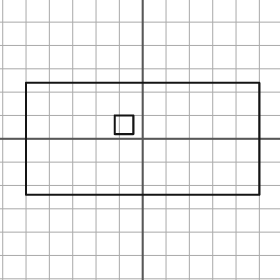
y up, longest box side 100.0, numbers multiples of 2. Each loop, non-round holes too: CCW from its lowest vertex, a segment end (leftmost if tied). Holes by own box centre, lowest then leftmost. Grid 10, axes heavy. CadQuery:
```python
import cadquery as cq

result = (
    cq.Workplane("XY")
    .moveTo(-50.0, -24.0)
    .lineTo(50.0, -24.0)
    .lineTo(50.0, 24.0)
    .lineTo(-50.0, 24.0)
    .close()
    .moveTo(-12.0, 2.0)
    .lineTo(-4.0, 2.0)
    .lineTo(-4.0, 10.0)
    .lineTo(-12.0, 10.0)
    .close()
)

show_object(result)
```